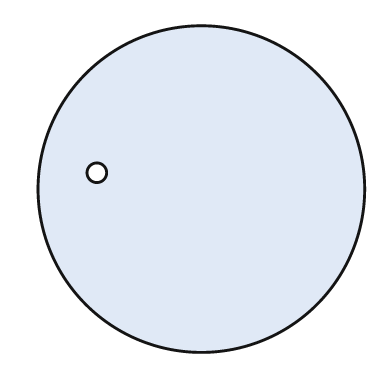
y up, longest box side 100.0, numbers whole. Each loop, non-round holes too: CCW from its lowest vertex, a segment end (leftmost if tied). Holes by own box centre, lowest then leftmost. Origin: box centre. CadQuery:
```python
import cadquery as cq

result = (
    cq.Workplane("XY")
    .moveTo(0.0, 0.0)
    .circle(50.0)
    .moveTo(-32.0, 5.0)
    .circle(3.0)
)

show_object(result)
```